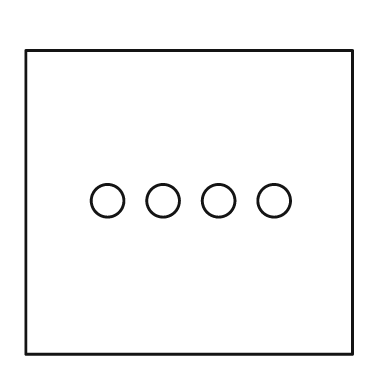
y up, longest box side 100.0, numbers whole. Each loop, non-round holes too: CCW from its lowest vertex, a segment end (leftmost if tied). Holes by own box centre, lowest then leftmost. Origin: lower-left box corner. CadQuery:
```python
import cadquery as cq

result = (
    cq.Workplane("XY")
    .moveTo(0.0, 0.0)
    .lineTo(100.0, 0.0)
    .lineTo(100.0, 93.0)
    .lineTo(0.0, 93.0)
    .close()
    .moveTo(25.0, 47.0)
    .circle(5.0)
    .moveTo(42.0, 47.0)
    .circle(5.0)
    .moveTo(59.0, 47.0)
    .circle(5.0)
    .moveTo(76.0, 47.0)
    .circle(5.0)
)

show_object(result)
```